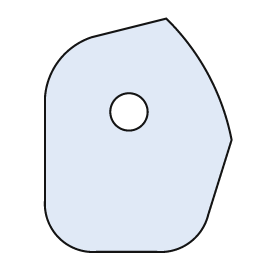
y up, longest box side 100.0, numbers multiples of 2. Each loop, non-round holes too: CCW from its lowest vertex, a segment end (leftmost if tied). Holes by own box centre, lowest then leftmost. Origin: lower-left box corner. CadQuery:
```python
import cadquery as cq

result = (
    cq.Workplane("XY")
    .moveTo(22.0, 0.0)
    .lineTo(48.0, 0.0)
    .threePointArc((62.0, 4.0), (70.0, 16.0))
    .lineTo(80.0, 48.0)
    .threePointArc((70.0, 76.0), (52.0, 100.0))
    .lineTo(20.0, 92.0)
    .threePointArc((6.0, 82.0), (0.0, 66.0))
    .lineTo(0.0, 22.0)
    .threePointArc((6.0, 6.0), (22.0, 0.0))
    .close()
    .moveTo(36.0, 60.0)
    .circle(8.0)
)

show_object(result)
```